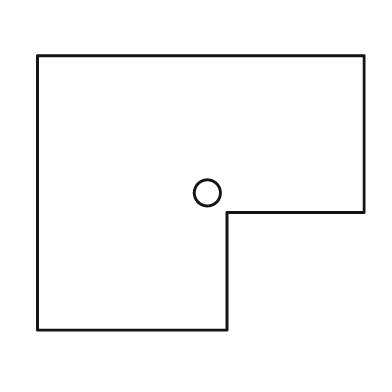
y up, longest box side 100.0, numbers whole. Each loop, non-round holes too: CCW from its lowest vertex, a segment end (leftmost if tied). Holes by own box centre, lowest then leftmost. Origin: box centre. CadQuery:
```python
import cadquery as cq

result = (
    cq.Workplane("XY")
    .moveTo(-50.0, -42.0)
    .lineTo(8.0, -42.0)
    .lineTo(8.0, -6.0)
    .lineTo(50.0, -6.0)
    .lineTo(50.0, 42.0)
    .lineTo(-50.0, 42.0)
    .close()
    .moveTo(2.0, 0.0)
    .circle(4.0)
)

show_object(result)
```